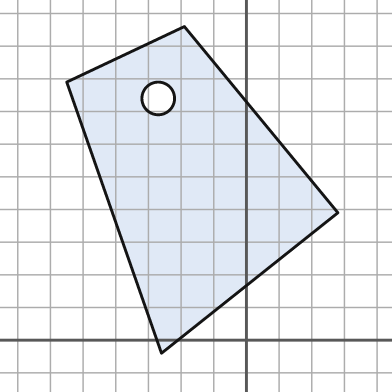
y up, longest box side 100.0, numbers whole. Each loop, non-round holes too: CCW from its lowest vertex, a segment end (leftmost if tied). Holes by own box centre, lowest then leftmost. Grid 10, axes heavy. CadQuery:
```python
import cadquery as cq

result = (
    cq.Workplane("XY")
    .moveTo(-26.0, -4.0)
    .lineTo(28.0, 39.0)
    .lineTo(-19.0, 96.0)
    .lineTo(-55.0, 79.0)
    .close()
    .moveTo(-27.0, 74.0)
    .circle(5.0)
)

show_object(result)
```